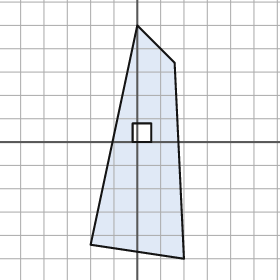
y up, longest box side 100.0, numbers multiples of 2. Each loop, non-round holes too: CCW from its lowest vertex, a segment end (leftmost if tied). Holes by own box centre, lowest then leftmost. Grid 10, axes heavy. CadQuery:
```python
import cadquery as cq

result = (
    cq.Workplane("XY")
    .moveTo(20.0, -50.0)
    .lineTo(16.0, 34.0)
    .lineTo(0.0, 50.0)
    .lineTo(-20.0, -44.0)
    .close()
    .moveTo(-2.0, 0.0)
    .lineTo(6.0, 0.0)
    .lineTo(6.0, 8.0)
    .lineTo(-2.0, 8.0)
    .close()
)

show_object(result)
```